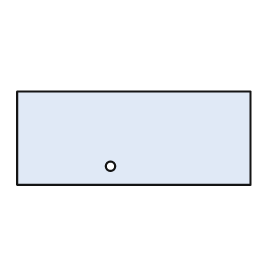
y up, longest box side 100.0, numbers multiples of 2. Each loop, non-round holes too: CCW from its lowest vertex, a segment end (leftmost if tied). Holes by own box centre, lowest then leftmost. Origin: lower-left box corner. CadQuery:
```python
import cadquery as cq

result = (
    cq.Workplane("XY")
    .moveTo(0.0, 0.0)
    .lineTo(100.0, 0.0)
    .lineTo(100.0, 40.0)
    .lineTo(0.0, 40.0)
    .close()
    .moveTo(40.0, 8.0)
    .circle(2.0)
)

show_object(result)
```